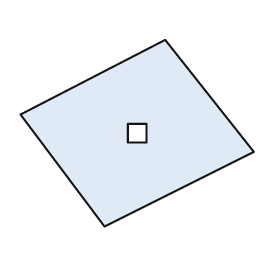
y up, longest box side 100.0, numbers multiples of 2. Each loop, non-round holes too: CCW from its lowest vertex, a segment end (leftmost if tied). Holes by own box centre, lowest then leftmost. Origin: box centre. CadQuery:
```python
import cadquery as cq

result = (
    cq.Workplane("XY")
    .moveTo(-14.0, -40.0)
    .lineTo(50.0, -8.0)
    .lineTo(12.0, 40.0)
    .lineTo(-50.0, 8.0)
    .close()
    .moveTo(-4.0, -4.0)
    .lineTo(4.0, -4.0)
    .lineTo(4.0, 4.0)
    .lineTo(-4.0, 4.0)
    .close()
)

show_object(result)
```